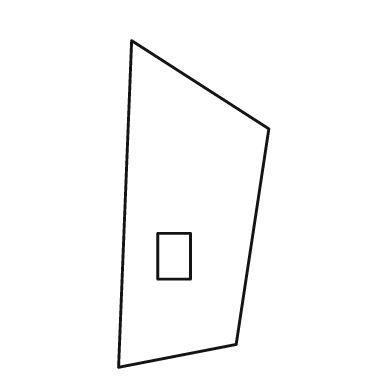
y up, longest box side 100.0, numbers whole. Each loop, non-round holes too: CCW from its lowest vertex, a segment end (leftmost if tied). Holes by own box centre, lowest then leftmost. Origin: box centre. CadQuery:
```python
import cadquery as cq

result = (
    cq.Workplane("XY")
    .moveTo(-23.0, -50.0)
    .lineTo(13.0, -43.0)
    .lineTo(23.0, 23.0)
    .lineTo(-19.0, 50.0)
    .close()
    .moveTo(-11.0, -23.0)
    .lineTo(-1.0, -23.0)
    .lineTo(-1.0, -9.0)
    .lineTo(-11.0, -9.0)
    .close()
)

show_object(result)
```